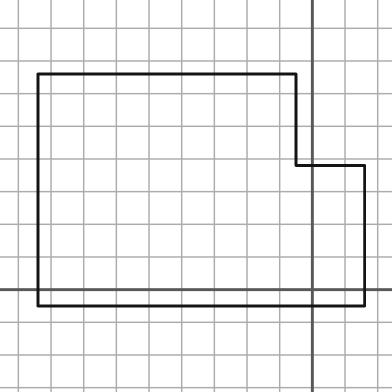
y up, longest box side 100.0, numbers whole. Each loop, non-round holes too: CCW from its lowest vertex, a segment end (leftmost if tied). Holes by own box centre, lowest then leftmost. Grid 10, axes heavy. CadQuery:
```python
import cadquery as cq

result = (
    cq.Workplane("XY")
    .moveTo(-84.0, -5.0)
    .lineTo(16.0, -5.0)
    .lineTo(16.0, 38.0)
    .lineTo(-5.0, 38.0)
    .lineTo(-5.0, 66.0)
    .lineTo(-84.0, 66.0)
    .close()
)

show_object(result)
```